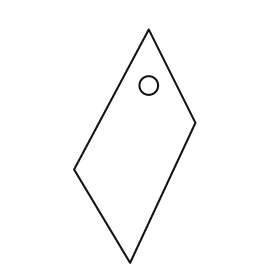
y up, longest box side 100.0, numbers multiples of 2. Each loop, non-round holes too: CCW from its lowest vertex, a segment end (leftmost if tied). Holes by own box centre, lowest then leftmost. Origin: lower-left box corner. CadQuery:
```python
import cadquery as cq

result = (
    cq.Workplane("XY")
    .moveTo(24.0, 0.0)
    .lineTo(52.0, 60.0)
    .lineTo(32.0, 100.0)
    .lineTo(0.0, 40.0)
    .close()
    .moveTo(32.0, 76.0)
    .circle(4.0)
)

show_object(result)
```